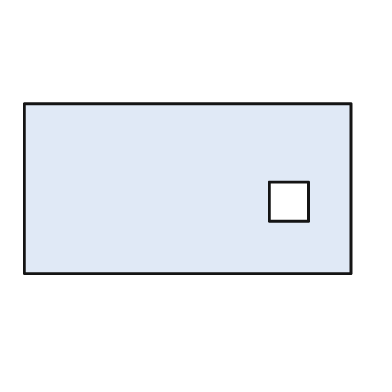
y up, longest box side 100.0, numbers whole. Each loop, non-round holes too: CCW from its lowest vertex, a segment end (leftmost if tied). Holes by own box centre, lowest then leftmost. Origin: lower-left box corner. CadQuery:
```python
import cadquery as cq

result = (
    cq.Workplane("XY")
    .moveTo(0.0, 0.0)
    .lineTo(100.0, 0.0)
    .lineTo(100.0, 52.0)
    .lineTo(0.0, 52.0)
    .close()
    .moveTo(75.0, 16.0)
    .lineTo(87.0, 16.0)
    .lineTo(87.0, 28.0)
    .lineTo(75.0, 28.0)
    .close()
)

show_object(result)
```